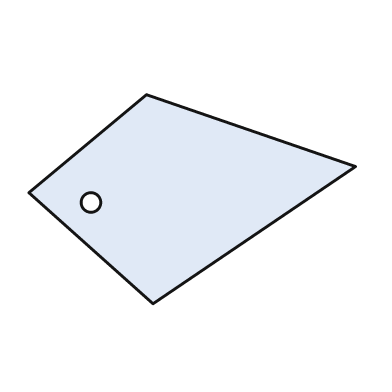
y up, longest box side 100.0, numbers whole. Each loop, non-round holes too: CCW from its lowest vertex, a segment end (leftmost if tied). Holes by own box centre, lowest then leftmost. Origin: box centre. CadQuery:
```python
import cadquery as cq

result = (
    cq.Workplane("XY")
    .moveTo(-12.0, -32.0)
    .lineTo(50.0, 10.0)
    .lineTo(-14.0, 32.0)
    .lineTo(-50.0, 2.0)
    .close()
    .moveTo(-31.0, -1.0)
    .circle(3.0)
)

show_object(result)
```